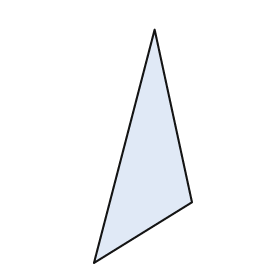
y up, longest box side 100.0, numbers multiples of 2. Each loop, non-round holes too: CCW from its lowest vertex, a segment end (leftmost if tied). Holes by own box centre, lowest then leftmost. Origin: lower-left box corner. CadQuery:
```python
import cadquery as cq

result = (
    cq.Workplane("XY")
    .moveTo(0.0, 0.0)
    .lineTo(42.0, 26.0)
    .lineTo(26.0, 100.0)
    .close()
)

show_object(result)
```